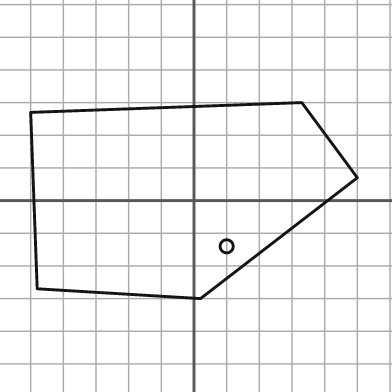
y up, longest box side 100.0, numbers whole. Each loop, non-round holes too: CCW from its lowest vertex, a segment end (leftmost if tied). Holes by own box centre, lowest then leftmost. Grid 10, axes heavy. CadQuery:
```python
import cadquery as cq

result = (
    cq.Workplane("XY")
    .moveTo(2.0, -30.0)
    .lineTo(50.0, 7.0)
    .lineTo(33.0, 30.0)
    .lineTo(-50.0, 27.0)
    .lineTo(-48.0, -27.0)
    .close()
    .moveTo(10.0, -14.0)
    .circle(2.0)
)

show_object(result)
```